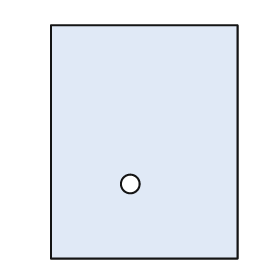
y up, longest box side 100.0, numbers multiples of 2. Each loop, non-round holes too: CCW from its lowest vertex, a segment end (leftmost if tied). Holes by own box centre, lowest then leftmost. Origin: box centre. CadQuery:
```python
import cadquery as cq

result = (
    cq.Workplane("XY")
    .moveTo(-40.0, -50.0)
    .lineTo(40.0, -50.0)
    .lineTo(40.0, 50.0)
    .lineTo(-40.0, 50.0)
    .close()
    .moveTo(-6.0, -18.0)
    .circle(4.0)
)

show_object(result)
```